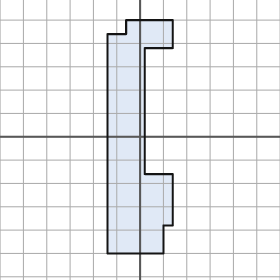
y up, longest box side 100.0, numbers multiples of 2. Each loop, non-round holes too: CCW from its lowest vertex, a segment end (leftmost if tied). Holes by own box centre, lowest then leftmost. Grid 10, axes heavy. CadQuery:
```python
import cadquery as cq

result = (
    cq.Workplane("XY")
    .moveTo(-14.0, -50.0)
    .lineTo(10.0, -50.0)
    .lineTo(10.0, -38.0)
    .lineTo(14.0, -38.0)
    .lineTo(14.0, -16.0)
    .lineTo(2.0, -16.0)
    .lineTo(2.0, 38.0)
    .lineTo(14.0, 38.0)
    .lineTo(14.0, 50.0)
    .lineTo(-6.0, 50.0)
    .lineTo(-6.0, 44.0)
    .lineTo(-14.0, 44.0)
    .close()
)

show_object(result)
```